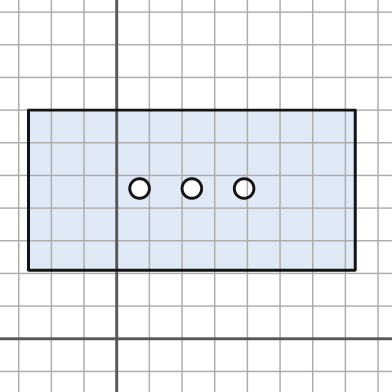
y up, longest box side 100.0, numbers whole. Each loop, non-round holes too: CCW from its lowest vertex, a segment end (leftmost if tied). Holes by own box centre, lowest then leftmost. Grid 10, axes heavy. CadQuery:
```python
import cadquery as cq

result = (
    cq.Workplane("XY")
    .moveTo(-27.0, 21.0)
    .lineTo(73.0, 21.0)
    .lineTo(73.0, 70.0)
    .lineTo(-27.0, 70.0)
    .close()
    .moveTo(7.0, 46.0)
    .circle(3.0)
    .moveTo(23.0, 46.0)
    .circle(3.0)
    .moveTo(39.0, 46.0)
    .circle(3.0)
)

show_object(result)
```